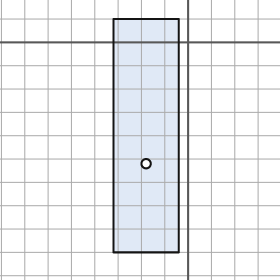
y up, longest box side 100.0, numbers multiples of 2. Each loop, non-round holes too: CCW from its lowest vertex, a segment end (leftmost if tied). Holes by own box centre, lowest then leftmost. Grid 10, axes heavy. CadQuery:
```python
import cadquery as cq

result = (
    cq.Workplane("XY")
    .moveTo(-32.0, -90.0)
    .lineTo(-4.0, -90.0)
    .lineTo(-4.0, 10.0)
    .lineTo(-32.0, 10.0)
    .close()
    .moveTo(-18.0, -52.0)
    .circle(2.0)
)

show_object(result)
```